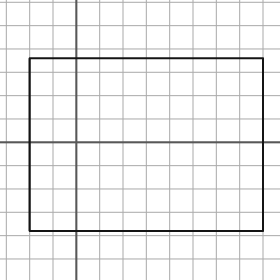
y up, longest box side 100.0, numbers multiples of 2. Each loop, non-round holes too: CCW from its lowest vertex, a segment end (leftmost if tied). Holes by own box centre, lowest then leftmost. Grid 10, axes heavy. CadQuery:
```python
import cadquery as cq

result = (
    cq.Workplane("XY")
    .moveTo(-20.0, -38.0)
    .lineTo(80.0, -38.0)
    .lineTo(80.0, 36.0)
    .lineTo(-20.0, 36.0)
    .close()
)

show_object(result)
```